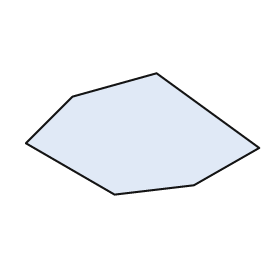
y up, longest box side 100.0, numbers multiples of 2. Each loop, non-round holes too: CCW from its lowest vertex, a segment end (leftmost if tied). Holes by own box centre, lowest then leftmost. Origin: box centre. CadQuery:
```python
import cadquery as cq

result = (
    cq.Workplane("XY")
    .moveTo(-12.0, -26.0)
    .lineTo(22.0, -22.0)
    .lineTo(50.0, -6.0)
    .lineTo(6.0, 26.0)
    .lineTo(-30.0, 16.0)
    .lineTo(-50.0, -4.0)
    .close()
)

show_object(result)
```